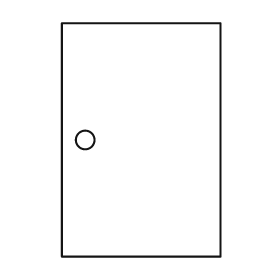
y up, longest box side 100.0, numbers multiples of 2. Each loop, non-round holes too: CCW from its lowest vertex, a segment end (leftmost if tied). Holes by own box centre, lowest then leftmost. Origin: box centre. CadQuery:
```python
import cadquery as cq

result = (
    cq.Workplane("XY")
    .moveTo(-34.0, -50.0)
    .lineTo(34.0, -50.0)
    .lineTo(34.0, 50.0)
    .lineTo(-34.0, 50.0)
    .close()
    .moveTo(-24.0, 0.0)
    .circle(4.0)
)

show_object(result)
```